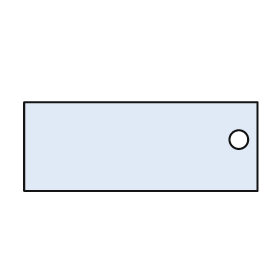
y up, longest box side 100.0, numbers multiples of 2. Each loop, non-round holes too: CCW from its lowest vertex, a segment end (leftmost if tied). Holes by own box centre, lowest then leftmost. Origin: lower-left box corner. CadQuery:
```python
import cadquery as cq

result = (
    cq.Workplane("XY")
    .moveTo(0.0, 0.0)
    .lineTo(100.0, 0.0)
    .lineTo(100.0, 38.0)
    .lineTo(0.0, 38.0)
    .close()
    .moveTo(92.0, 22.0)
    .circle(4.0)
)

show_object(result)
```